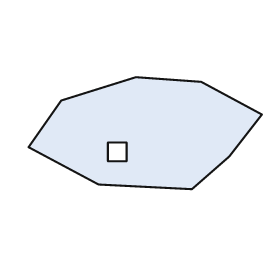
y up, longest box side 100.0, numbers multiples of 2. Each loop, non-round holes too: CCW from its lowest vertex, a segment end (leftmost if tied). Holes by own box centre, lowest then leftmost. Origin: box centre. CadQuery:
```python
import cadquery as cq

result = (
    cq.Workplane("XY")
    .moveTo(20.0, -24.0)
    .lineTo(36.0, -10.0)
    .lineTo(50.0, 8.0)
    .lineTo(24.0, 22.0)
    .lineTo(-4.0, 24.0)
    .lineTo(-36.0, 14.0)
    .lineTo(-50.0, -6.0)
    .lineTo(-20.0, -22.0)
    .close()
    .moveTo(-16.0, -12.0)
    .lineTo(-8.0, -12.0)
    .lineTo(-8.0, -4.0)
    .lineTo(-16.0, -4.0)
    .close()
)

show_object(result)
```